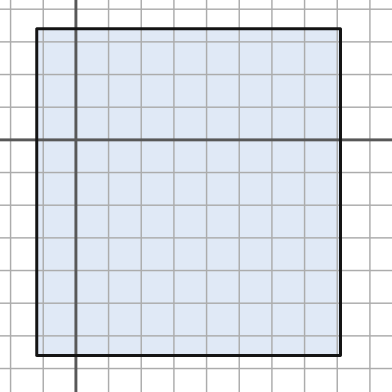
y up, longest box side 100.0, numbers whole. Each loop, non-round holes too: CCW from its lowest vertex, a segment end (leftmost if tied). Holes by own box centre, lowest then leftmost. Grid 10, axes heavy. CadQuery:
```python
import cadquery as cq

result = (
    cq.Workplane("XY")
    .moveTo(-12.0, -66.0)
    .lineTo(81.0, -66.0)
    .lineTo(81.0, 34.0)
    .lineTo(-12.0, 34.0)
    .close()
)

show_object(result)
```